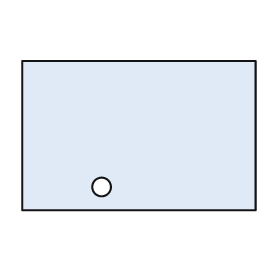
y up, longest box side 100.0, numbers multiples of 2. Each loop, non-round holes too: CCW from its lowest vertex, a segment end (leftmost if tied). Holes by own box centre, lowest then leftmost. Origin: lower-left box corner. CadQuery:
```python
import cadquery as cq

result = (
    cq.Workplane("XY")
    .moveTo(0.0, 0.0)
    .lineTo(100.0, 0.0)
    .lineTo(100.0, 64.0)
    .lineTo(0.0, 64.0)
    .close()
    .moveTo(34.0, 10.0)
    .circle(4.0)
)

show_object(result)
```